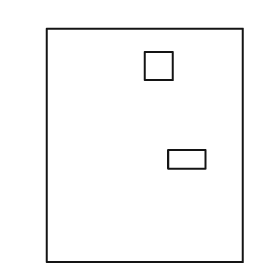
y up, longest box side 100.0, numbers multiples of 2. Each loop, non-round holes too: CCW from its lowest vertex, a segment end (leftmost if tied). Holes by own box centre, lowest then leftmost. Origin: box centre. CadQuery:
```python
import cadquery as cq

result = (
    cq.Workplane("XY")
    .moveTo(-42.0, -50.0)
    .lineTo(42.0, -50.0)
    .lineTo(42.0, 50.0)
    .lineTo(-42.0, 50.0)
    .close()
    .moveTo(10.0, -10.0)
    .lineTo(26.0, -10.0)
    .lineTo(26.0, -2.0)
    .lineTo(10.0, -2.0)
    .close()
    .moveTo(0.0, 28.0)
    .lineTo(12.0, 28.0)
    .lineTo(12.0, 40.0)
    .lineTo(0.0, 40.0)
    .close()
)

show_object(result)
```